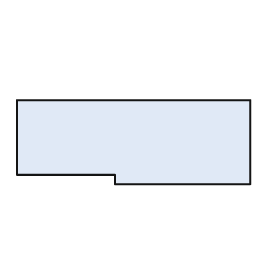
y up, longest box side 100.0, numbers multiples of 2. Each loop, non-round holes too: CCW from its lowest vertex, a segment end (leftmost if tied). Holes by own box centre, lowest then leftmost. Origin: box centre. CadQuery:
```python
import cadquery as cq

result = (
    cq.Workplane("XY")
    .moveTo(-8.0, -18.0)
    .lineTo(50.0, -18.0)
    .lineTo(50.0, 18.0)
    .lineTo(-50.0, 18.0)
    .lineTo(-50.0, -14.0)
    .lineTo(-8.0, -14.0)
    .close()
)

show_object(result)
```